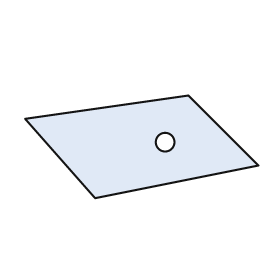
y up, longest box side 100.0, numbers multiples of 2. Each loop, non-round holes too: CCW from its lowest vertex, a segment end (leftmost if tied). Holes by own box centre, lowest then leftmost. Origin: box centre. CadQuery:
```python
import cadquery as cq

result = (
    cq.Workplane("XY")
    .moveTo(-20.0, -22.0)
    .lineTo(50.0, -8.0)
    .lineTo(20.0, 22.0)
    .lineTo(-50.0, 12.0)
    .close()
    .moveTo(10.0, 2.0)
    .circle(4.0)
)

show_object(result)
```